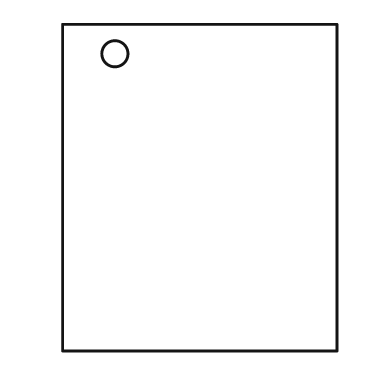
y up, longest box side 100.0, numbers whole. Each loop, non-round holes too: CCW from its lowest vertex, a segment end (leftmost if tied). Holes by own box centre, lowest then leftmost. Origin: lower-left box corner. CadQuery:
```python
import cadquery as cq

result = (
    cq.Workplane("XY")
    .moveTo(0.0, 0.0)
    .lineTo(84.0, 0.0)
    .lineTo(84.0, 100.0)
    .lineTo(0.0, 100.0)
    .close()
    .moveTo(16.0, 91.0)
    .circle(4.0)
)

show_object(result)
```